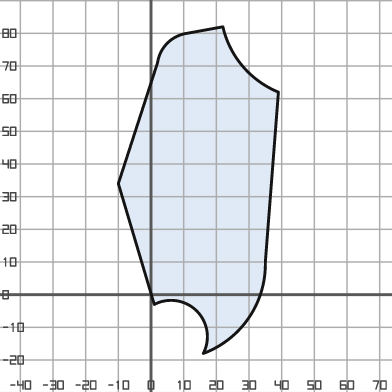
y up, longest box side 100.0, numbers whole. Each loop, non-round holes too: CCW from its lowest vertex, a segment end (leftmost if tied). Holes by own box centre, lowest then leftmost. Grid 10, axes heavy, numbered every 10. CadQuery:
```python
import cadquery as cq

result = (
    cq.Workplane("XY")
    .moveTo(16.0, -18.0)
    .threePointArc((30.0, -7.0), (35.0, 10.0))
    .lineTo(39.0, 62.0)
    .threePointArc((28.0, 70.0), (22.0, 82.0))
    .lineTo(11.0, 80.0)
    .threePointArc((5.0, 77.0), (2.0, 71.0))
    .lineTo(-10.0, 34.0)
    .lineTo(1.0, -3.0)
    .threePointArc((14.0, -5.0), (16.0, -18.0))
    .close()
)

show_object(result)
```